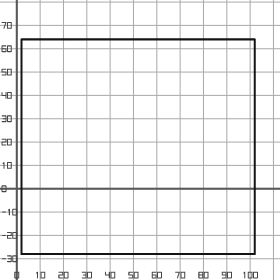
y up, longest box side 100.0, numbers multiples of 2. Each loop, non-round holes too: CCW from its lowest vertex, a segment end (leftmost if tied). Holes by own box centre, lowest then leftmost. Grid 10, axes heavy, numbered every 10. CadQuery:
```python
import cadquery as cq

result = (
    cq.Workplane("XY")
    .moveTo(2.0, -28.0)
    .lineTo(102.0, -28.0)
    .lineTo(102.0, 64.0)
    .lineTo(2.0, 64.0)
    .close()
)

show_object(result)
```